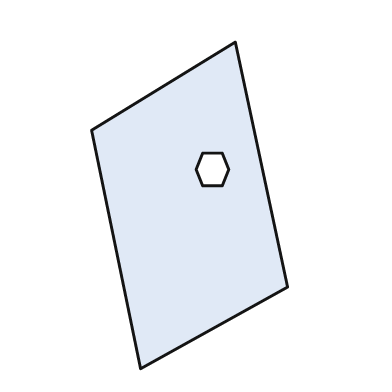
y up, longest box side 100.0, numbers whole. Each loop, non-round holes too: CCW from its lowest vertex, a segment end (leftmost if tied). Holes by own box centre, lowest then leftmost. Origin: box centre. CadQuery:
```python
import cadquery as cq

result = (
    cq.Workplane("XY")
    .moveTo(-15.0, -50.0)
    .lineTo(30.0, -25.0)
    .lineTo(14.0, 50.0)
    .lineTo(-30.0, 23.0)
    .close()
    .moveTo(4.0, 6.0)
    .lineTo(10.0, 6.0)
    .lineTo(12.0, 11.0)
    .lineTo(10.0, 16.0)
    .lineTo(4.0, 16.0)
    .lineTo(2.0, 11.0)
    .close()
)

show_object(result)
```